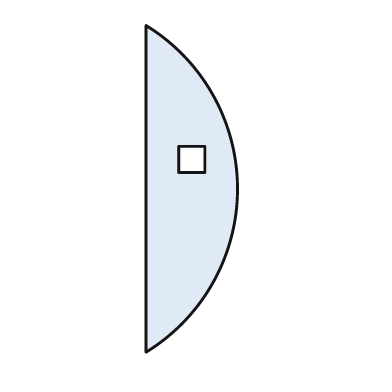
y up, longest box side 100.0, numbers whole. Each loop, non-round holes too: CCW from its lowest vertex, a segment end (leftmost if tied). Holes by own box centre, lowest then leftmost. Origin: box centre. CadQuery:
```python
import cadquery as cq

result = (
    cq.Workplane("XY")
    .moveTo(-14.0, -50.0)
    .threePointArc((14.0, 0.0), (-14.0, 50.0))
    .close()
    .moveTo(-4.0, 5.0)
    .lineTo(4.0, 5.0)
    .lineTo(4.0, 13.0)
    .lineTo(-4.0, 13.0)
    .close()
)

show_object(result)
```